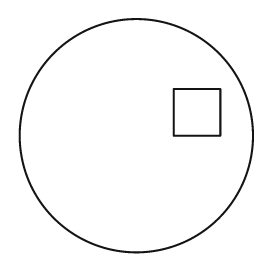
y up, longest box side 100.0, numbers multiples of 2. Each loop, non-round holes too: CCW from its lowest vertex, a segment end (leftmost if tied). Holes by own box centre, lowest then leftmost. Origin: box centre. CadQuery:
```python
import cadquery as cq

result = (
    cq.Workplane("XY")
    .moveTo(0.0, 0.0)
    .circle(50.0)
    .moveTo(16.0, 0.0)
    .lineTo(36.0, 0.0)
    .lineTo(36.0, 20.0)
    .lineTo(16.0, 20.0)
    .close()
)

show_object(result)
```